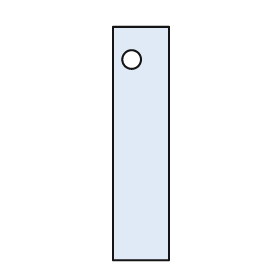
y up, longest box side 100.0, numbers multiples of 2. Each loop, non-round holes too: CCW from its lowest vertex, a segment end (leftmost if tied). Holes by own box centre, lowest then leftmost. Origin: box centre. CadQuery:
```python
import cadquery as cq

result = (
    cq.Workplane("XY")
    .moveTo(-12.0, -50.0)
    .lineTo(12.0, -50.0)
    .lineTo(12.0, 50.0)
    .lineTo(-12.0, 50.0)
    .close()
    .moveTo(-4.0, 36.0)
    .circle(4.0)
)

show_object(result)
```